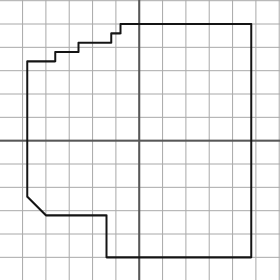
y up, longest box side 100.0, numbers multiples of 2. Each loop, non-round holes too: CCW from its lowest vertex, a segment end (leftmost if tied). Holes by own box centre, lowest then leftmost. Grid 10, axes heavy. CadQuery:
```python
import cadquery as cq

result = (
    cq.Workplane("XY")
    .moveTo(-14.0, -50.0)
    .lineTo(48.0, -50.0)
    .lineTo(48.0, 50.0)
    .lineTo(-8.0, 50.0)
    .lineTo(-8.0, 46.0)
    .lineTo(-12.0, 46.0)
    .lineTo(-12.0, 42.0)
    .lineTo(-26.0, 42.0)
    .lineTo(-26.0, 38.0)
    .lineTo(-36.0, 38.0)
    .lineTo(-36.0, 34.0)
    .lineTo(-48.0, 34.0)
    .lineTo(-48.0, -24.0)
    .lineTo(-40.0, -32.0)
    .lineTo(-14.0, -32.0)
    .close()
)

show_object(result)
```